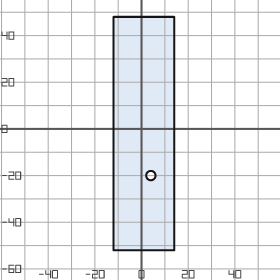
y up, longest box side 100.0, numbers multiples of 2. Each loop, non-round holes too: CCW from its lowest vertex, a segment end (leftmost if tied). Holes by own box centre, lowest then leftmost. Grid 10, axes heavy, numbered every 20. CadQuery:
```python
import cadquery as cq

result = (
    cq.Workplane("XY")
    .moveTo(-12.0, -52.0)
    .lineTo(14.0, -52.0)
    .lineTo(14.0, 48.0)
    .lineTo(-12.0, 48.0)
    .close()
    .moveTo(4.0, -20.0)
    .circle(2.0)
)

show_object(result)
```